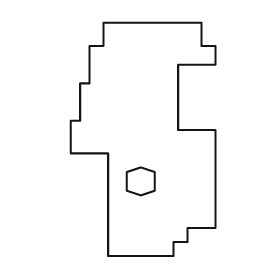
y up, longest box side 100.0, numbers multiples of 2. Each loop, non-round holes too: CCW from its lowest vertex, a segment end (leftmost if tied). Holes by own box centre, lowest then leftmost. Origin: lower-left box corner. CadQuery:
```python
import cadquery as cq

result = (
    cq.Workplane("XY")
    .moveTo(16.0, 0.0)
    .lineTo(44.0, 0.0)
    .lineTo(44.0, 6.0)
    .lineTo(50.0, 6.0)
    .lineTo(50.0, 12.0)
    .lineTo(62.0, 12.0)
    .lineTo(62.0, 54.0)
    .lineTo(46.0, 54.0)
    .lineTo(46.0, 82.0)
    .lineTo(62.0, 82.0)
    .lineTo(62.0, 90.0)
    .lineTo(56.0, 90.0)
    .lineTo(56.0, 100.0)
    .lineTo(14.0, 100.0)
    .lineTo(14.0, 90.0)
    .lineTo(8.0, 90.0)
    .lineTo(8.0, 74.0)
    .lineTo(4.0, 74.0)
    .lineTo(4.0, 58.0)
    .lineTo(0.0, 58.0)
    .lineTo(0.0, 44.0)
    .lineTo(16.0, 44.0)
    .close()
    .moveTo(30.0, 26.0)
    .lineTo(36.0, 28.0)
    .lineTo(36.0, 36.0)
    .lineTo(30.0, 38.0)
    .lineTo(24.0, 36.0)
    .lineTo(24.0, 28.0)
    .close()
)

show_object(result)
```